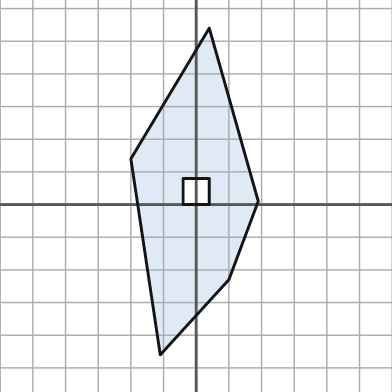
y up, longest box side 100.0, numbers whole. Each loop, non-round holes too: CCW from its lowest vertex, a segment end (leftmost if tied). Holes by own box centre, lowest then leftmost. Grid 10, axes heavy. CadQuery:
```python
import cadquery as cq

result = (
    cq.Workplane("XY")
    .moveTo(-11.0, -46.0)
    .lineTo(10.0, -23.0)
    .lineTo(19.0, 1.0)
    .lineTo(4.0, 54.0)
    .lineTo(-20.0, 14.0)
    .close()
    .moveTo(-4.0, 0.0)
    .lineTo(4.0, 0.0)
    .lineTo(4.0, 8.0)
    .lineTo(-4.0, 8.0)
    .close()
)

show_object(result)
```